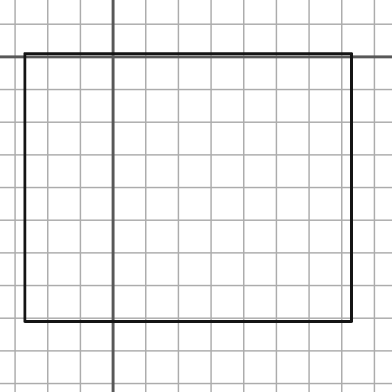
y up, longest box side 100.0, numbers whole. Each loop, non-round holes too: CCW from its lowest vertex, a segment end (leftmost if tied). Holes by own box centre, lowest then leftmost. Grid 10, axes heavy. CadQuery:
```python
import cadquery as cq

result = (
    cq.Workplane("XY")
    .moveTo(-27.0, -81.0)
    .lineTo(73.0, -81.0)
    .lineTo(73.0, 1.0)
    .lineTo(-27.0, 1.0)
    .close()
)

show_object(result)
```